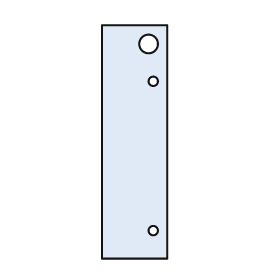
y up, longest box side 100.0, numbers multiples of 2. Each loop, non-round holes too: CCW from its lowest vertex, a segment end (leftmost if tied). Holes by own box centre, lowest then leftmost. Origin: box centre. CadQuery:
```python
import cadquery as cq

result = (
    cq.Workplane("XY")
    .moveTo(-14.0, -50.0)
    .lineTo(14.0, -50.0)
    .lineTo(14.0, 50.0)
    .lineTo(-14.0, 50.0)
    .close()
    .moveTo(8.0, -38.0)
    .circle(2.0)
    .moveTo(8.0, 26.0)
    .circle(2.0)
    .moveTo(6.0, 42.0)
    .circle(4.0)
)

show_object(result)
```